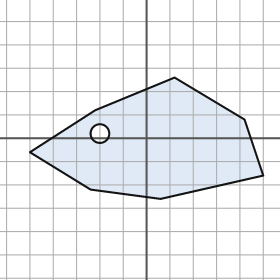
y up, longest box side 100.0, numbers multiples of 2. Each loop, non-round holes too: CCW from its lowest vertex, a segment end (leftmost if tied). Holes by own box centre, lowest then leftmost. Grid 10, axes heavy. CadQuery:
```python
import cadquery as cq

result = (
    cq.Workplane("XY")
    .moveTo(6.0, -26.0)
    .lineTo(50.0, -16.0)
    .lineTo(42.0, 8.0)
    .lineTo(12.0, 26.0)
    .lineTo(-22.0, 12.0)
    .lineTo(-50.0, -6.0)
    .lineTo(-24.0, -22.0)
    .close()
    .moveTo(-20.0, 2.0)
    .circle(4.0)
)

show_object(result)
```